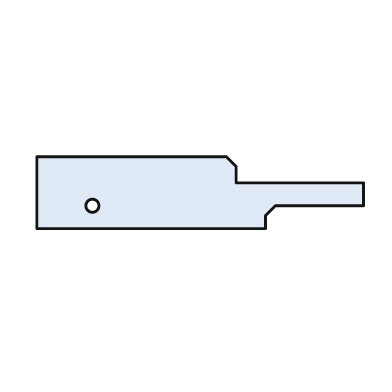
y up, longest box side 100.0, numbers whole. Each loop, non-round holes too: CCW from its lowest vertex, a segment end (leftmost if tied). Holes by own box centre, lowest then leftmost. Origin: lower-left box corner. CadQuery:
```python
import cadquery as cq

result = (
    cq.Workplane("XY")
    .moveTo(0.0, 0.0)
    .lineTo(70.0, 0.0)
    .lineTo(70.0, 4.0)
    .lineTo(73.0, 7.0)
    .lineTo(100.0, 7.0)
    .lineTo(100.0, 14.0)
    .lineTo(61.0, 14.0)
    .lineTo(61.0, 19.0)
    .lineTo(58.0, 22.0)
    .lineTo(0.0, 22.0)
    .close()
    .moveTo(17.0, 7.0)
    .circle(2.0)
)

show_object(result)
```